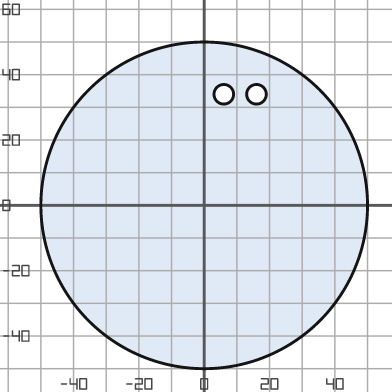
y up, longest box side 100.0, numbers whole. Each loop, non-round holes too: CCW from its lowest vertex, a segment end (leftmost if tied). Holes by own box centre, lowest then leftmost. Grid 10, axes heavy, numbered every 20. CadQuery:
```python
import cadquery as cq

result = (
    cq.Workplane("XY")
    .moveTo(0.0, 0.0)
    .circle(50.0)
    .moveTo(6.0, 34.0)
    .circle(3.0)
    .moveTo(16.0, 34.0)
    .circle(3.0)
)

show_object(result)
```